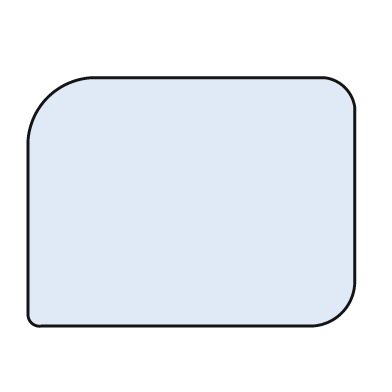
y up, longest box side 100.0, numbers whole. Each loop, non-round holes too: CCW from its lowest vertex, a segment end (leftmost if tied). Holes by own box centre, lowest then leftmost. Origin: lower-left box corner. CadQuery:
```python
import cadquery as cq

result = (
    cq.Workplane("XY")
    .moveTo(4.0, 0.0)
    .lineTo(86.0, 0.0)
    .threePointArc((96.0, 4.0), (100.0, 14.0))
    .lineTo(100.0, 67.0)
    .threePointArc((97.0, 73.0), (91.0, 76.0))
    .lineTo(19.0, 76.0)
    .threePointArc((6.0, 70.0), (0.0, 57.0))
    .lineTo(0.0, 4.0)
    .threePointArc((1.0, 1.0), (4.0, 0.0))
    .close()
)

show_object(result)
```